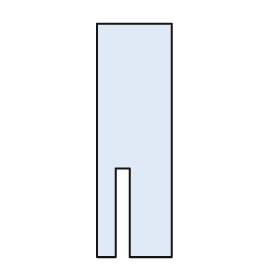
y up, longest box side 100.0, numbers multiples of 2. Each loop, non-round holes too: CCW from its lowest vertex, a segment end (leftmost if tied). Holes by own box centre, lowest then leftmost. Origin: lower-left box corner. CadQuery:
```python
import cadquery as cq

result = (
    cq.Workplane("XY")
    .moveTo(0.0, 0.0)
    .lineTo(8.0, 0.0)
    .lineTo(8.0, 38.0)
    .lineTo(14.0, 38.0)
    .lineTo(14.0, 0.0)
    .lineTo(32.0, 0.0)
    .lineTo(32.0, 100.0)
    .lineTo(0.0, 100.0)
    .close()
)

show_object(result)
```